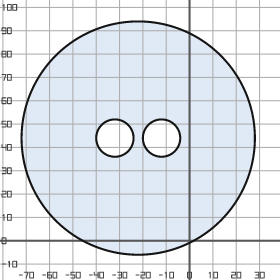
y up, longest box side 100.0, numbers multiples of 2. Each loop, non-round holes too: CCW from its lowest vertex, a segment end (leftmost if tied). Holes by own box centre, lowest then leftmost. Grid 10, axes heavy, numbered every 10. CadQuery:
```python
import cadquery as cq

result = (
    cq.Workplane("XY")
    .moveTo(-22.0, 44.0)
    .circle(50.0)
    .moveTo(-32.0, 44.0)
    .circle(8.0)
    .moveTo(-12.0, 44.0)
    .circle(8.0)
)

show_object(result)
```